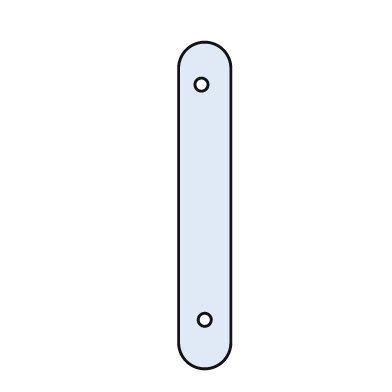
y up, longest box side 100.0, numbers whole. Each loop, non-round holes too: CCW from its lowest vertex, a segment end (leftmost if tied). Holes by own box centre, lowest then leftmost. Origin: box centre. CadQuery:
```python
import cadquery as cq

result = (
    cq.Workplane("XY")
    .moveTo(-8.0, -42.0)
    .threePointArc((0.0, -50.0), (8.0, -42.0))
    .lineTo(8.0, 42.0)
    .threePointArc((0.0, 50.0), (-8.0, 42.0))
    .close()
    .moveTo(0.0, -35.0)
    .circle(2.0)
    .moveTo(-1.0, 37.0)
    .circle(2.0)
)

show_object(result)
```